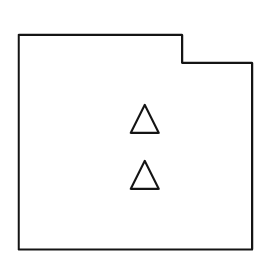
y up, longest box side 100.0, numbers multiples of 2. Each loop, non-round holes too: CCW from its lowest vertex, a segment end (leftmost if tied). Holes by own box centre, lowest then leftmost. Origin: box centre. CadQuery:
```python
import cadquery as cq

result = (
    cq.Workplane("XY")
    .moveTo(-50.0, -46.0)
    .lineTo(50.0, -46.0)
    .lineTo(50.0, 34.0)
    .lineTo(20.0, 34.0)
    .lineTo(20.0, 46.0)
    .lineTo(-50.0, 46.0)
    .close()
    .moveTo(-2.0, -20.0)
    .lineTo(10.0, -20.0)
    .lineTo(4.0, -8.0)
    .close()
    .moveTo(-2.0, 4.0)
    .lineTo(10.0, 4.0)
    .lineTo(4.0, 16.0)
    .close()
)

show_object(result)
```